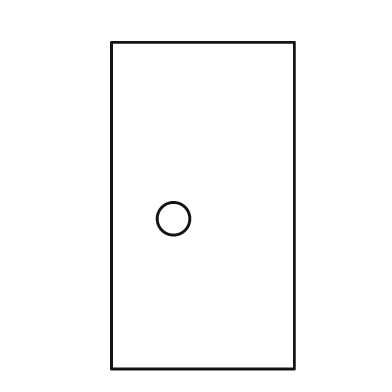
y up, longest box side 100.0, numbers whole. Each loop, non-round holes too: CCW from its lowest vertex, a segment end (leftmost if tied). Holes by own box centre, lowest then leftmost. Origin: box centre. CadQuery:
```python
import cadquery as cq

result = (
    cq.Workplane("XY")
    .moveTo(-28.0, -50.0)
    .lineTo(28.0, -50.0)
    .lineTo(28.0, 50.0)
    .lineTo(-28.0, 50.0)
    .close()
    .moveTo(-9.0, -4.0)
    .circle(5.0)
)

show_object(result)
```